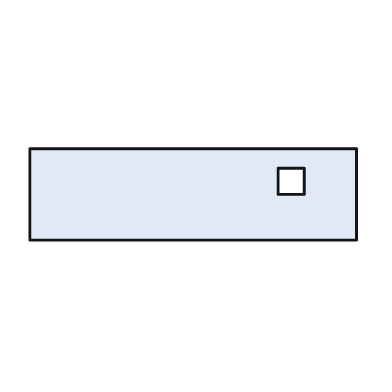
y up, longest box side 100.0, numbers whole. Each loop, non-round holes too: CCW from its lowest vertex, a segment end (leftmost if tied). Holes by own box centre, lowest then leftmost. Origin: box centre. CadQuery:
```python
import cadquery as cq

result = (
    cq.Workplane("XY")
    .moveTo(-50.0, -14.0)
    .lineTo(50.0, -14.0)
    .lineTo(50.0, 14.0)
    .lineTo(-50.0, 14.0)
    .close()
    .moveTo(26.0, 0.0)
    .lineTo(34.0, 0.0)
    .lineTo(34.0, 8.0)
    .lineTo(26.0, 8.0)
    .close()
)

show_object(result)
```